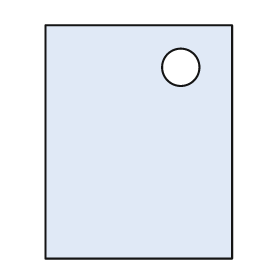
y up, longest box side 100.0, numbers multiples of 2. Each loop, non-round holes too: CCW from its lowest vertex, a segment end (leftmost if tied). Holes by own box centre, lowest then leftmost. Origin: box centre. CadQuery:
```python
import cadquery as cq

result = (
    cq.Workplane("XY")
    .moveTo(-40.0, -50.0)
    .lineTo(40.0, -50.0)
    .lineTo(40.0, 50.0)
    .lineTo(-40.0, 50.0)
    .close()
    .moveTo(18.0, 32.0)
    .circle(8.0)
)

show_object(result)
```